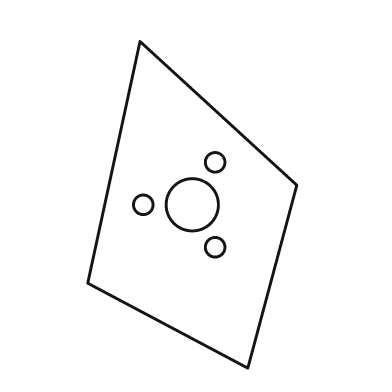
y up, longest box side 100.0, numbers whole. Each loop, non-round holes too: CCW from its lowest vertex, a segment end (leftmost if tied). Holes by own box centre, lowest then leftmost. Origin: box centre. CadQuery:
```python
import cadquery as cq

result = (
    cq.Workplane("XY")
    .moveTo(17.0, -50.0)
    .lineTo(32.0, 6.0)
    .lineTo(-16.0, 50.0)
    .lineTo(-32.0, -24.0)
    .close()
    .moveTo(7.0, -13.0)
    .circle(3.0)
    .moveTo(-15.0, 0.0)
    .circle(3.0)
    .moveTo(0.0, 0.0)
    .circle(8.0)
    .moveTo(7.0, 13.0)
    .circle(3.0)
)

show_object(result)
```